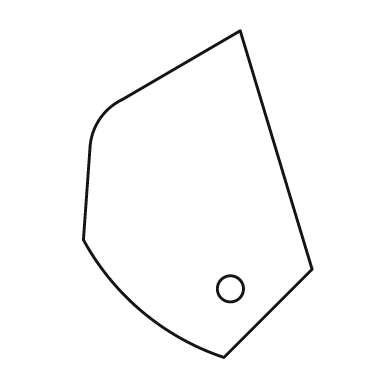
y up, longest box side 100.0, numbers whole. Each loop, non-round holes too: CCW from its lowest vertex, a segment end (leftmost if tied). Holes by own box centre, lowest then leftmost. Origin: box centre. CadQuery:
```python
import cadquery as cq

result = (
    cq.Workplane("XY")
    .moveTo(8.0, -50.0)
    .lineTo(35.0, -23.0)
    .lineTo(13.0, 50.0)
    .lineTo(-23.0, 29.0)
    .threePointArc((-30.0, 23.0), (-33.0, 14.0))
    .lineTo(-35.0, -14.0)
    .threePointArc((-17.0, -36.0), (8.0, -50.0))
    .close()
    .moveTo(10.0, -29.0)
    .circle(4.0)
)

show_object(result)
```